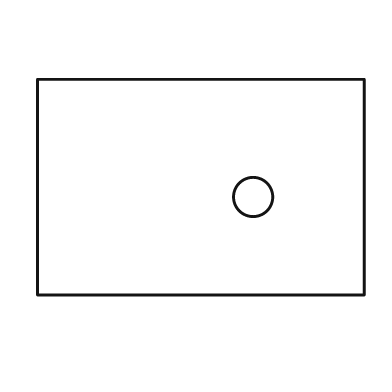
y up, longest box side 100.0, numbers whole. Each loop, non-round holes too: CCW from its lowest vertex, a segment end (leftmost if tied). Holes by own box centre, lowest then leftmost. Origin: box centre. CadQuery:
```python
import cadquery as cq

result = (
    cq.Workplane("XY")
    .moveTo(-50.0, -33.0)
    .lineTo(50.0, -33.0)
    .lineTo(50.0, 33.0)
    .lineTo(-50.0, 33.0)
    .close()
    .moveTo(16.0, -3.0)
    .circle(6.0)
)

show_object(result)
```